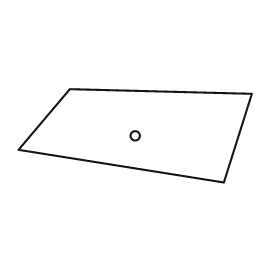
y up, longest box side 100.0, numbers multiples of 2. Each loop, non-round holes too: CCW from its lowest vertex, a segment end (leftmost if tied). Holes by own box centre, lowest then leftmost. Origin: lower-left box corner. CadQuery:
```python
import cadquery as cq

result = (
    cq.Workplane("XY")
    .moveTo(88.0, 0.0)
    .lineTo(100.0, 38.0)
    .lineTo(22.0, 40.0)
    .lineTo(0.0, 14.0)
    .close()
    .moveTo(50.0, 20.0)
    .circle(2.0)
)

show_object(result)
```